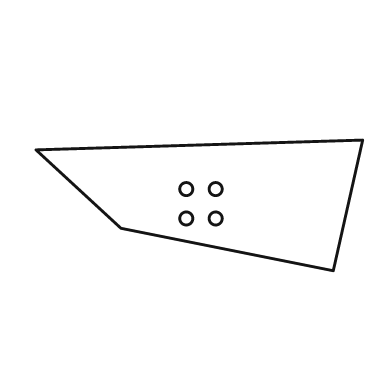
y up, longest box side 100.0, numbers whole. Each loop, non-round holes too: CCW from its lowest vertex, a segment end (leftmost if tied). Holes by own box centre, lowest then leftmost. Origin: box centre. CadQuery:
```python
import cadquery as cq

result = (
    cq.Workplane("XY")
    .moveTo(41.0, -20.0)
    .lineTo(50.0, 20.0)
    .lineTo(-50.0, 17.0)
    .lineTo(-24.0, -7.0)
    .close()
    .moveTo(-4.0, -4.0)
    .circle(2.0)
    .moveTo(5.0, -4.0)
    .circle(2.0)
    .moveTo(-4.0, 5.0)
    .circle(2.0)
    .moveTo(5.0, 5.0)
    .circle(2.0)
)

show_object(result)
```